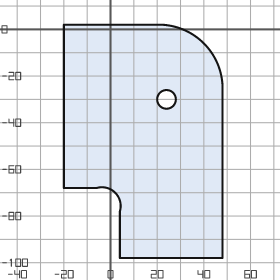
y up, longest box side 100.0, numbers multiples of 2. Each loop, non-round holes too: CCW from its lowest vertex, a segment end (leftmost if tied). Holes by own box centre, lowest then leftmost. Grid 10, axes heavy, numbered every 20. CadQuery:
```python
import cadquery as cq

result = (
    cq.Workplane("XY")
    .moveTo(4.0, -98.0)
    .lineTo(48.0, -98.0)
    .lineTo(48.0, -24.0)
    .threePointArc((40.0, -6.0), (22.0, 2.0))
    .lineTo(-20.0, 2.0)
    .lineTo(-20.0, -68.0)
    .lineTo(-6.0, -68.0)
    .threePointArc((2.0, -70.0), (4.0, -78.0))
    .close()
    .moveTo(24.0, -30.0)
    .circle(4.0)
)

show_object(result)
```